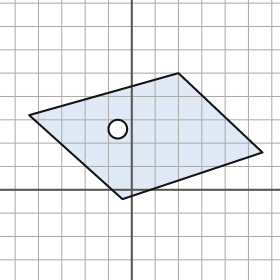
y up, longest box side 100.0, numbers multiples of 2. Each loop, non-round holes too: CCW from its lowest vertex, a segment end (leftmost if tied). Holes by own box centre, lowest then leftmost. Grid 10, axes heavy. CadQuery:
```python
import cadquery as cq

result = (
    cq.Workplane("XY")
    .moveTo(-4.0, -4.0)
    .lineTo(56.0, 16.0)
    .lineTo(20.0, 50.0)
    .lineTo(-44.0, 32.0)
    .close()
    .moveTo(-6.0, 26.0)
    .circle(4.0)
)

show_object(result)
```